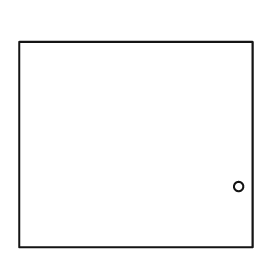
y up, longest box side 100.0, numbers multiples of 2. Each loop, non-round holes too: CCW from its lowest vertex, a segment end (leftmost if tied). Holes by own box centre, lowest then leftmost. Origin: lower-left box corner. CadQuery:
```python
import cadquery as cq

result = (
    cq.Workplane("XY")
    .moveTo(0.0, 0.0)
    .lineTo(100.0, 0.0)
    .lineTo(100.0, 88.0)
    .lineTo(0.0, 88.0)
    .close()
    .moveTo(94.0, 26.0)
    .circle(2.0)
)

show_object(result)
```